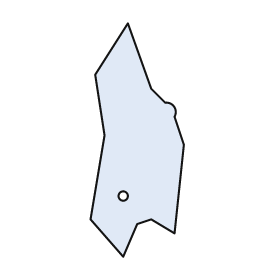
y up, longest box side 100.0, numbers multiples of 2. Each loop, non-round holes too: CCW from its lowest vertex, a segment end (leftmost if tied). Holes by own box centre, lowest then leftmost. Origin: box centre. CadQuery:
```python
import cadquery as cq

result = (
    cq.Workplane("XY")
    .moveTo(-6.0, -50.0)
    .lineTo(0.0, -36.0)
    .lineTo(6.0, -34.0)
    .lineTo(16.0, -40.0)
    .lineTo(20.0, -2.0)
    .lineTo(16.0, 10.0)
    .threePointArc((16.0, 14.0), (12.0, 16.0))
    .lineTo(6.0, 22.0)
    .lineTo(-4.0, 50.0)
    .lineTo(-18.0, 28.0)
    .lineTo(-14.0, 2.0)
    .lineTo(-20.0, -34.0)
    .close()
    .moveTo(-6.0, -24.0)
    .circle(2.0)
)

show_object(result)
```